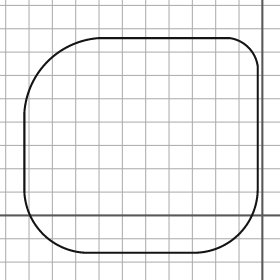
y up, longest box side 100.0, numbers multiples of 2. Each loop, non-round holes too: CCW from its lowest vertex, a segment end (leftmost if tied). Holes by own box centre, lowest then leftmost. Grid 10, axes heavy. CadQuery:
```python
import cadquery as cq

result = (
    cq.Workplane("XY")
    .moveTo(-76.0, -16.0)
    .lineTo(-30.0, -16.0)
    .threePointArc((-10.0, -8.0), (-2.0, 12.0))
    .lineTo(-2.0, 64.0)
    .threePointArc((-6.0, 72.0), (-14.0, 76.0))
    .lineTo(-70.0, 76.0)
    .threePointArc((-92.0, 66.0), (-102.0, 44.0))
    .lineTo(-102.0, 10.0)
    .threePointArc((-94.0, -8.0), (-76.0, -16.0))
    .close()
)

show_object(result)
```